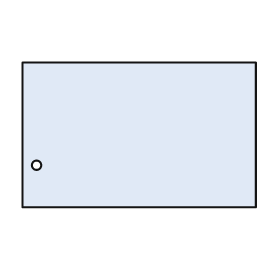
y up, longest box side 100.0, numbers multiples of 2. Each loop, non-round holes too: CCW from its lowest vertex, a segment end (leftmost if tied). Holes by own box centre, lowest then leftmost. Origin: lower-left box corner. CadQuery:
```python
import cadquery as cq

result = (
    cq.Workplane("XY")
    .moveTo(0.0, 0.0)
    .lineTo(100.0, 0.0)
    .lineTo(100.0, 62.0)
    .lineTo(0.0, 62.0)
    .close()
    .moveTo(6.0, 18.0)
    .circle(2.0)
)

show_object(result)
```